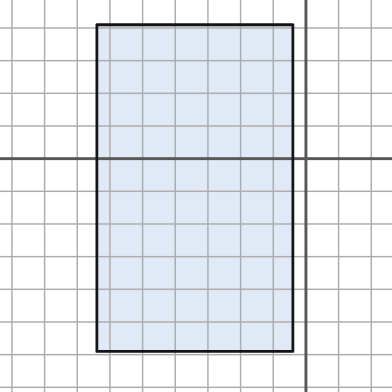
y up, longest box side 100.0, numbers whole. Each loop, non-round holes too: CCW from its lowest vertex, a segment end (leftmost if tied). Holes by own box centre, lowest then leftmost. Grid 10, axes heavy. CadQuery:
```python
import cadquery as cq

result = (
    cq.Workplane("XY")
    .moveTo(-64.0, -59.0)
    .lineTo(-4.0, -59.0)
    .lineTo(-4.0, 41.0)
    .lineTo(-64.0, 41.0)
    .close()
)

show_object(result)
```